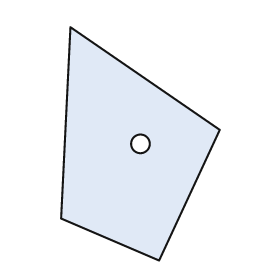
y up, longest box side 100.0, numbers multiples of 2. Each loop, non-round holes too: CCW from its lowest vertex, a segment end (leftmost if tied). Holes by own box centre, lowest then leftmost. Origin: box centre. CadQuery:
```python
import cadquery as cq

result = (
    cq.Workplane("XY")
    .moveTo(8.0, -50.0)
    .lineTo(34.0, 6.0)
    .lineTo(-30.0, 50.0)
    .lineTo(-34.0, -32.0)
    .close()
    .moveTo(0.0, 0.0)
    .circle(4.0)
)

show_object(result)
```